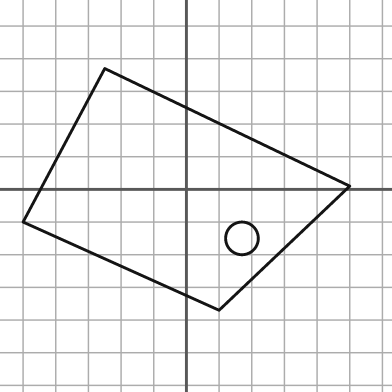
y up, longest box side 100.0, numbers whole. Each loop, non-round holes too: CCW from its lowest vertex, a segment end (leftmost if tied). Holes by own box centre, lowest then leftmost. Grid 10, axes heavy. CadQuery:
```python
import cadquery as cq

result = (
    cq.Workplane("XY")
    .moveTo(10.0, -37.0)
    .lineTo(50.0, 1.0)
    .lineTo(-25.0, 37.0)
    .lineTo(-50.0, -10.0)
    .close()
    .moveTo(17.0, -15.0)
    .circle(5.0)
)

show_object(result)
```